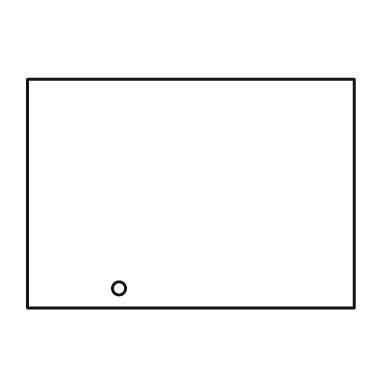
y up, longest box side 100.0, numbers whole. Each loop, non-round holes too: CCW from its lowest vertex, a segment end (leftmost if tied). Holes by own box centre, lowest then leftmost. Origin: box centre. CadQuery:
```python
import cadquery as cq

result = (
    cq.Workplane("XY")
    .moveTo(-50.0, -35.0)
    .lineTo(50.0, -35.0)
    .lineTo(50.0, 35.0)
    .lineTo(-50.0, 35.0)
    .close()
    .moveTo(-22.0, -29.0)
    .circle(2.0)
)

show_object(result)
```